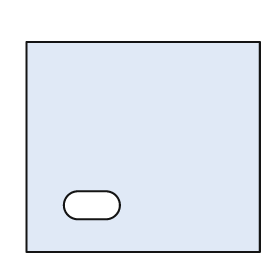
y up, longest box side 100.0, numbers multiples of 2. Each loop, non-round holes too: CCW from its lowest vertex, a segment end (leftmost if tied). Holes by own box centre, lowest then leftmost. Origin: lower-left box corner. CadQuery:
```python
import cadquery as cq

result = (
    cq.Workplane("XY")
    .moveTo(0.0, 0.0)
    .lineTo(100.0, 0.0)
    .lineTo(100.0, 90.0)
    .lineTo(0.0, 90.0)
    .close()
    .moveTo(22.0, 14.0)
    .lineTo(34.0, 14.0)
    .threePointArc((40.0, 20.0), (34.0, 26.0))
    .lineTo(22.0, 26.0)
    .threePointArc((16.0, 20.0), (22.0, 14.0))
    .close()
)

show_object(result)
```